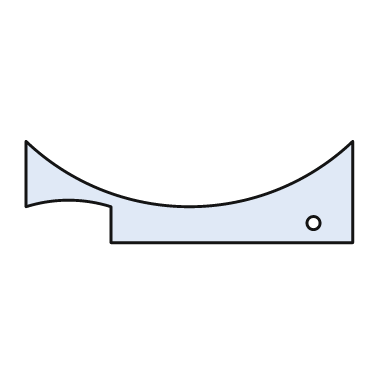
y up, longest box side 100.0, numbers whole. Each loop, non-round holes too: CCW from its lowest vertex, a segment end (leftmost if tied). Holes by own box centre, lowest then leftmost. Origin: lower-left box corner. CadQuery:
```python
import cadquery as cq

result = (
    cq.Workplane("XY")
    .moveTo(26.0, 0.0)
    .lineTo(100.0, 0.0)
    .lineTo(100.0, 31.0)
    .threePointArc((50.0, 11.0), (0.0, 31.0))
    .lineTo(0.0, 11.0)
    .threePointArc((13.0, 13.0), (26.0, 11.0))
    .close()
    .moveTo(88.0, 6.0)
    .circle(2.0)
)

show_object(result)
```